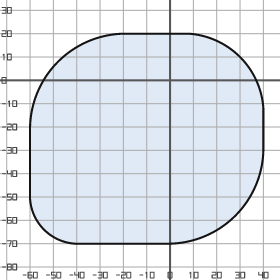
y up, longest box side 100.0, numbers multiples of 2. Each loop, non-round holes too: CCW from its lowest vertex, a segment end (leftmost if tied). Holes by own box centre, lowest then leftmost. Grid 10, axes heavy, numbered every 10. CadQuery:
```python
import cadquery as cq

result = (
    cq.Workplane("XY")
    .moveTo(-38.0, -70.0)
    .lineTo(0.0, -70.0)
    .threePointArc((28.0, -58.0), (40.0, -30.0))
    .lineTo(40.0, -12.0)
    .threePointArc((30.0, 10.0), (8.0, 20.0))
    .lineTo(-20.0, 20.0)
    .threePointArc((-48.0, 8.0), (-60.0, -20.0))
    .lineTo(-60.0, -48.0)
    .threePointArc((-54.0, -64.0), (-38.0, -70.0))
    .close()
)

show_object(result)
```